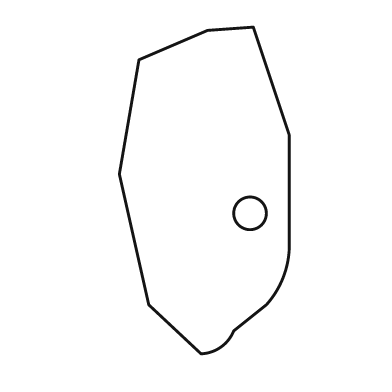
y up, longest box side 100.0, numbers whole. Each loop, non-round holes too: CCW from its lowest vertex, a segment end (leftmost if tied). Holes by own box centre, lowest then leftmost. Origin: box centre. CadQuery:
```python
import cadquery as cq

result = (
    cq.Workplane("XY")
    .moveTo(-1.0, -50.0)
    .threePointArc((5.0, -48.0), (9.0, -43.0))
    .lineTo(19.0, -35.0)
    .threePointArc((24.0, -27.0), (26.0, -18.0))
    .lineTo(26.0, 17.0)
    .lineTo(15.0, 50.0)
    .lineTo(1.0, 49.0)
    .lineTo(-20.0, 40.0)
    .lineTo(-26.0, 5.0)
    .lineTo(-17.0, -35.0)
    .close()
    .moveTo(14.0, -7.0)
    .circle(5.0)
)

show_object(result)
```